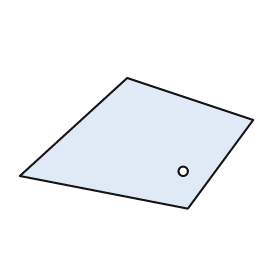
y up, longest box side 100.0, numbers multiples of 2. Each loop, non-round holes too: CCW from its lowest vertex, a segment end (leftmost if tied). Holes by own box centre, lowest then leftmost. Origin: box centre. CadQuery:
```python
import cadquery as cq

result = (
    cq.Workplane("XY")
    .moveTo(22.0, -28.0)
    .lineTo(50.0, 10.0)
    .lineTo(-4.0, 28.0)
    .lineTo(-50.0, -14.0)
    .close()
    .moveTo(20.0, -12.0)
    .circle(2.0)
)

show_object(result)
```